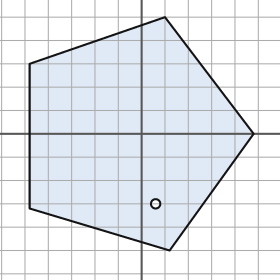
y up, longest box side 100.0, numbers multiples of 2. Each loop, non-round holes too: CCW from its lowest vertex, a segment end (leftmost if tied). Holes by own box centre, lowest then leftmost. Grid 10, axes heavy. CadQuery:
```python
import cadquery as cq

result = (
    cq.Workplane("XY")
    .moveTo(12.0, -50.0)
    .lineTo(48.0, 0.0)
    .lineTo(10.0, 50.0)
    .lineTo(-48.0, 30.0)
    .lineTo(-48.0, -32.0)
    .close()
    .moveTo(6.0, -30.0)
    .circle(2.0)
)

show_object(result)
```